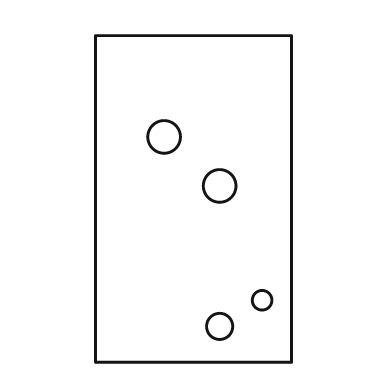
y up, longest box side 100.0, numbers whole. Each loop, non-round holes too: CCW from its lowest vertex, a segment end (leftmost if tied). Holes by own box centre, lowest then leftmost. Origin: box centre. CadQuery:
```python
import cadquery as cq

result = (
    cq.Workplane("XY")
    .moveTo(-30.0, -50.0)
    .lineTo(30.0, -50.0)
    .lineTo(30.0, 50.0)
    .lineTo(-30.0, 50.0)
    .close()
    .moveTo(8.0, -39.0)
    .circle(4.0)
    .moveTo(21.0, -31.0)
    .circle(3.0)
    .moveTo(8.0, 4.0)
    .circle(5.0)
    .moveTo(-9.0, 19.0)
    .circle(5.0)
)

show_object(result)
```